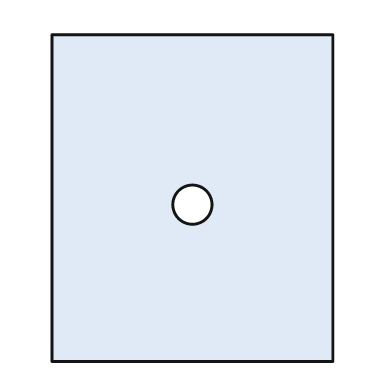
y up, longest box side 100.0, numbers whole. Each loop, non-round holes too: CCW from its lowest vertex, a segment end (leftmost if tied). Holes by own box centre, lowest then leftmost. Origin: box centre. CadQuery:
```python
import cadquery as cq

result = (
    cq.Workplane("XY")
    .moveTo(-43.0, -50.0)
    .lineTo(43.0, -50.0)
    .lineTo(43.0, 50.0)
    .lineTo(-43.0, 50.0)
    .close()
    .moveTo(0.0, -2.0)
    .circle(6.0)
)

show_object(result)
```